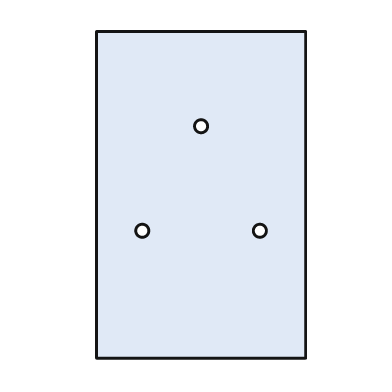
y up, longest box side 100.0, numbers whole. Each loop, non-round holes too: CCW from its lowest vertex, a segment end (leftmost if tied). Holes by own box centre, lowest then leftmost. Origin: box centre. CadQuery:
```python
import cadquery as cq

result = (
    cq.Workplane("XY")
    .moveTo(-32.0, -50.0)
    .lineTo(32.0, -50.0)
    .lineTo(32.0, 50.0)
    .lineTo(-32.0, 50.0)
    .close()
    .moveTo(-18.0, -11.0)
    .circle(2.0)
    .moveTo(18.0, -11.0)
    .circle(2.0)
    .moveTo(0.0, 21.0)
    .circle(2.0)
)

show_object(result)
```